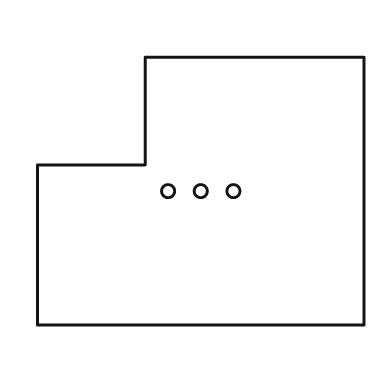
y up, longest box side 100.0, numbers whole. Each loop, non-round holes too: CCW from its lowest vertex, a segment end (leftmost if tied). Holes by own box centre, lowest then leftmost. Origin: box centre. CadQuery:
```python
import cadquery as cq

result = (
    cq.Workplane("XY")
    .moveTo(-50.0, -41.0)
    .lineTo(50.0, -41.0)
    .lineTo(50.0, 41.0)
    .lineTo(-17.0, 41.0)
    .lineTo(-17.0, 8.0)
    .lineTo(-50.0, 8.0)
    .close()
    .moveTo(-10.0, 0.0)
    .circle(2.0)
    .moveTo(0.0, 0.0)
    .circle(2.0)
    .moveTo(10.0, 0.0)
    .circle(2.0)
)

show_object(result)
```